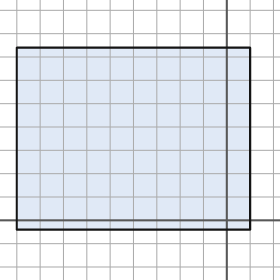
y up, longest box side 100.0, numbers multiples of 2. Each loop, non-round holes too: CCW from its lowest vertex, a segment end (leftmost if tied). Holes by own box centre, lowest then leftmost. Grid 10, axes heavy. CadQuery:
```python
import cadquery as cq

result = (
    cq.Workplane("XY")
    .moveTo(-90.0, -4.0)
    .lineTo(10.0, -4.0)
    .lineTo(10.0, 74.0)
    .lineTo(-90.0, 74.0)
    .close()
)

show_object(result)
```